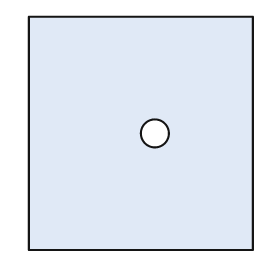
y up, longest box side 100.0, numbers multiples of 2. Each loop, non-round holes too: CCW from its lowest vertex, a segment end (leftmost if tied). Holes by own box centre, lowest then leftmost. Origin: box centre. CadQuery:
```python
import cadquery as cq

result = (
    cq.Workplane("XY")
    .moveTo(-48.0, -50.0)
    .lineTo(48.0, -50.0)
    .lineTo(48.0, 50.0)
    .lineTo(-48.0, 50.0)
    .close()
    .moveTo(6.0, 0.0)
    .circle(6.0)
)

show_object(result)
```